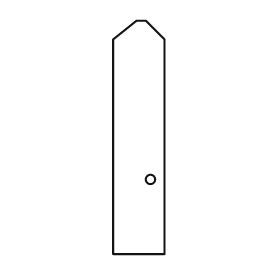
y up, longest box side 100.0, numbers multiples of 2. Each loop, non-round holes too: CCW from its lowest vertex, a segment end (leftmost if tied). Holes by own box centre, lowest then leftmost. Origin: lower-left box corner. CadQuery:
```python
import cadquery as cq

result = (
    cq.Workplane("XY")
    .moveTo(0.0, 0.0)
    .lineTo(22.0, 0.0)
    .lineTo(22.0, 92.0)
    .lineTo(14.0, 100.0)
    .lineTo(10.0, 100.0)
    .lineTo(0.0, 92.0)
    .close()
    .moveTo(16.0, 32.0)
    .circle(2.0)
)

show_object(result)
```